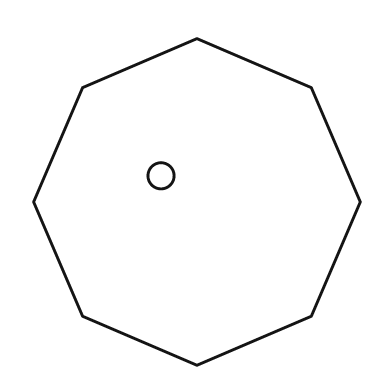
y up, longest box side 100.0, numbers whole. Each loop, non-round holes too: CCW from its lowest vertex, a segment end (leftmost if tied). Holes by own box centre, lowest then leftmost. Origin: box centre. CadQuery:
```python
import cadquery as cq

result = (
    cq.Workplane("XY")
    .moveTo(0.0, -50.0)
    .lineTo(35.0, -35.0)
    .lineTo(50.0, 0.0)
    .lineTo(35.0, 35.0)
    .lineTo(0.0, 50.0)
    .lineTo(-35.0, 35.0)
    .lineTo(-50.0, 0.0)
    .lineTo(-35.0, -35.0)
    .close()
    .moveTo(-11.0, 8.0)
    .circle(4.0)
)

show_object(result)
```